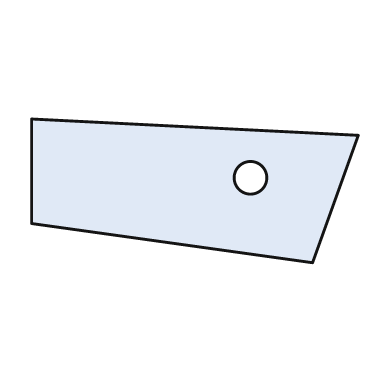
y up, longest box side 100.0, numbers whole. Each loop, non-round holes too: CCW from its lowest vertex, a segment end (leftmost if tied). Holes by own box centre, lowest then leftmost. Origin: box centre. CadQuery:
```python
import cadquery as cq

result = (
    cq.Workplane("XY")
    .moveTo(36.0, -22.0)
    .lineTo(50.0, 17.0)
    .lineTo(-50.0, 22.0)
    .lineTo(-50.0, -10.0)
    .close()
    .moveTo(17.0, 4.0)
    .circle(5.0)
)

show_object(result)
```